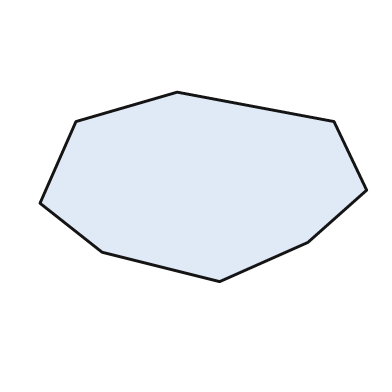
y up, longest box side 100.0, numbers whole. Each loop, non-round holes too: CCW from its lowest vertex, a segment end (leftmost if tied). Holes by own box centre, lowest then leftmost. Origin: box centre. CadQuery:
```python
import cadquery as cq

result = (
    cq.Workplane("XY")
    .moveTo(5.0, -29.0)
    .lineTo(32.0, -17.0)
    .lineTo(50.0, -1.0)
    .lineTo(40.0, 20.0)
    .lineTo(-8.0, 29.0)
    .lineTo(-39.0, 20.0)
    .lineTo(-50.0, -5.0)
    .lineTo(-31.0, -20.0)
    .close()
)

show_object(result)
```